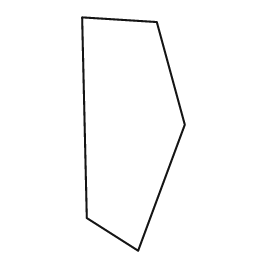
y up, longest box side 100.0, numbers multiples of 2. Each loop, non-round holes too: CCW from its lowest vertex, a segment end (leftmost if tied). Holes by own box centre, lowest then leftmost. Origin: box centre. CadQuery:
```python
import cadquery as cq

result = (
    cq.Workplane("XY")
    .moveTo(2.0, -50.0)
    .lineTo(22.0, 4.0)
    .lineTo(10.0, 48.0)
    .lineTo(-22.0, 50.0)
    .lineTo(-20.0, -36.0)
    .close()
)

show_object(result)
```